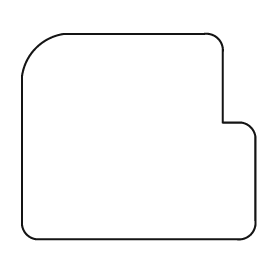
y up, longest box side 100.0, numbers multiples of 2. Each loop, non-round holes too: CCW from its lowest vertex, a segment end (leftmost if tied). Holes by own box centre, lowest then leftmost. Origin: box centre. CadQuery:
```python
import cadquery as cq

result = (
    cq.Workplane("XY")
    .moveTo(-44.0, -44.0)
    .lineTo(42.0, -44.0)
    .threePointArc((48.0, -42.0), (50.0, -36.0))
    .lineTo(50.0, 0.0)
    .threePointArc((48.0, 4.0), (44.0, 6.0))
    .lineTo(36.0, 6.0)
    .lineTo(36.0, 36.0)
    .threePointArc((34.0, 42.0), (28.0, 44.0))
    .lineTo(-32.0, 44.0)
    .threePointArc((-44.0, 38.0), (-50.0, 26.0))
    .lineTo(-50.0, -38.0)
    .threePointArc((-48.0, -42.0), (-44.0, -44.0))
    .close()
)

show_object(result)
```